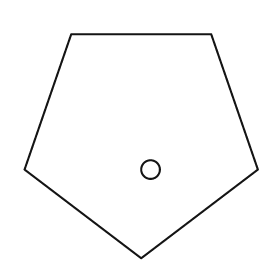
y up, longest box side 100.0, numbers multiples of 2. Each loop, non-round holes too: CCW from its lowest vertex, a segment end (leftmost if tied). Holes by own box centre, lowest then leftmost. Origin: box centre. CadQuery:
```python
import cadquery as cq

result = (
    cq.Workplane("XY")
    .moveTo(0.0, -48.0)
    .lineTo(50.0, -10.0)
    .lineTo(30.0, 48.0)
    .lineTo(-30.0, 48.0)
    .lineTo(-50.0, -10.0)
    .close()
    .moveTo(4.0, -10.0)
    .circle(4.0)
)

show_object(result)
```